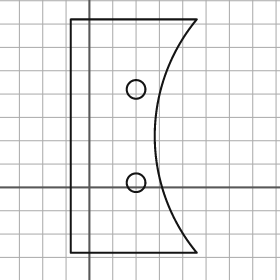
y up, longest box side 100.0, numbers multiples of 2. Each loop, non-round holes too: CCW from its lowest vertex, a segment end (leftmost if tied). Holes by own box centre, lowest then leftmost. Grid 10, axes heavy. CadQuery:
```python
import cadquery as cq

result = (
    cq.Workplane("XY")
    .moveTo(-8.0, -28.0)
    .lineTo(46.0, -28.0)
    .threePointArc((28.0, 22.0), (46.0, 72.0))
    .lineTo(-8.0, 72.0)
    .close()
    .moveTo(20.0, 2.0)
    .circle(4.0)
    .moveTo(20.0, 42.0)
    .circle(4.0)
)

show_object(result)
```